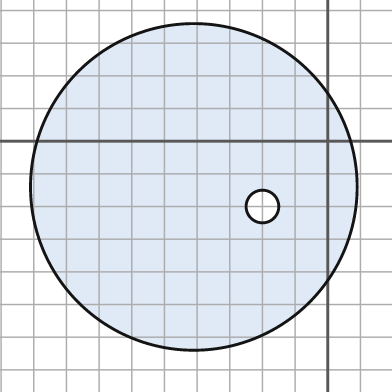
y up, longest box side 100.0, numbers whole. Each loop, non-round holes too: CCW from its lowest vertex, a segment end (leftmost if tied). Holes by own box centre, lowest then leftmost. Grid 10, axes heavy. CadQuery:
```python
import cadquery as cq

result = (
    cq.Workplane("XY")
    .moveTo(-41.0, -14.0)
    .circle(50.0)
    .moveTo(-20.0, -20.0)
    .circle(5.0)
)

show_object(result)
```